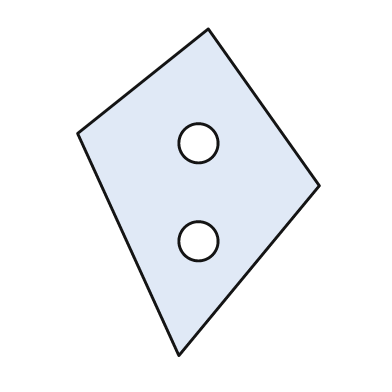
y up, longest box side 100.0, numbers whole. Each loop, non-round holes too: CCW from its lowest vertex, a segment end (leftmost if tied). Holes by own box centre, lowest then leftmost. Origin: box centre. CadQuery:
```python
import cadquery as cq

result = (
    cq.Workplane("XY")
    .moveTo(-6.0, -50.0)
    .lineTo(37.0, 2.0)
    .lineTo(3.0, 50.0)
    .lineTo(-37.0, 18.0)
    .close()
    .moveTo(0.0, -15.0)
    .circle(6.0)
    .moveTo(0.0, 15.0)
    .circle(6.0)
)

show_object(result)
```